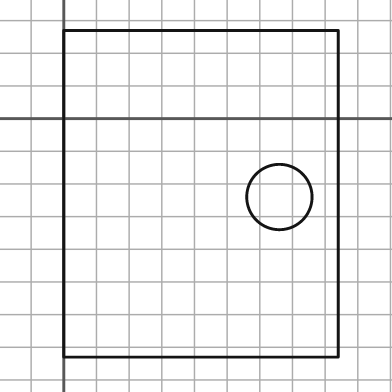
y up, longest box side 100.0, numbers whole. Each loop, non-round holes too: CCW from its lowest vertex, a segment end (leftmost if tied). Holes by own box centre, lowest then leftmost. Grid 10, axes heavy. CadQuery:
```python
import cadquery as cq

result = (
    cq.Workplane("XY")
    .moveTo(0.0, -73.0)
    .lineTo(84.0, -73.0)
    .lineTo(84.0, 27.0)
    .lineTo(0.0, 27.0)
    .close()
    .moveTo(66.0, -24.0)
    .circle(10.0)
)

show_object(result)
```